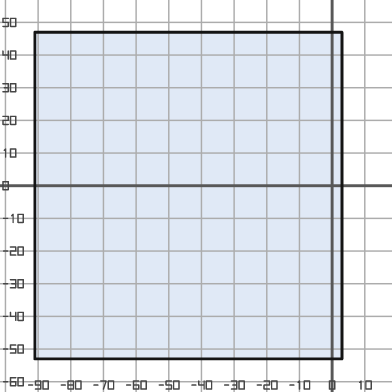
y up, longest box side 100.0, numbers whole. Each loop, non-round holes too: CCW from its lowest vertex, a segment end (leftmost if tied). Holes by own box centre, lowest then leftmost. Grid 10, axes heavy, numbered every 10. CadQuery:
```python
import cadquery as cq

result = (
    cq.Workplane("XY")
    .moveTo(-91.0, -53.0)
    .lineTo(3.0, -53.0)
    .lineTo(3.0, 47.0)
    .lineTo(-91.0, 47.0)
    .close()
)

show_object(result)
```